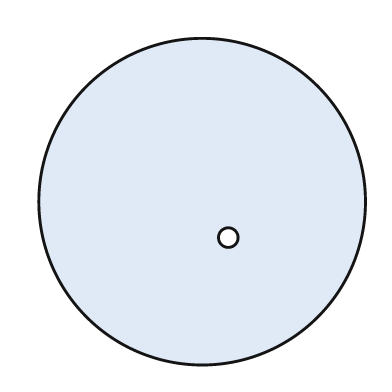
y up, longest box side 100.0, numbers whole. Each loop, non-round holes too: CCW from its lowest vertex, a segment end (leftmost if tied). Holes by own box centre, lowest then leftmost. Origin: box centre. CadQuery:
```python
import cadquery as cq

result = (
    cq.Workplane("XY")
    .moveTo(0.0, 0.0)
    .circle(50.0)
    .moveTo(8.0, -11.0)
    .circle(3.0)
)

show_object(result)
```